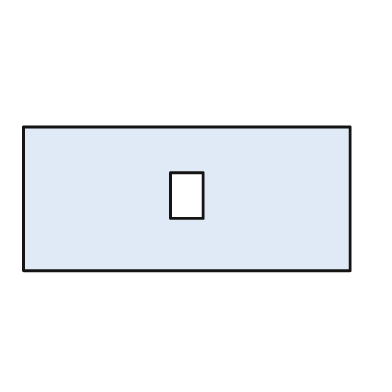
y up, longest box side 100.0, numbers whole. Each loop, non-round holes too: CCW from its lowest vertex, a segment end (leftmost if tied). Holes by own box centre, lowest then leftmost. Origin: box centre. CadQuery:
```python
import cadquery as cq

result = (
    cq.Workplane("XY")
    .moveTo(-50.0, -22.0)
    .lineTo(50.0, -22.0)
    .lineTo(50.0, 22.0)
    .lineTo(-50.0, 22.0)
    .close()
    .moveTo(-5.0, -6.0)
    .lineTo(5.0, -6.0)
    .lineTo(5.0, 8.0)
    .lineTo(-5.0, 8.0)
    .close()
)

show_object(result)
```